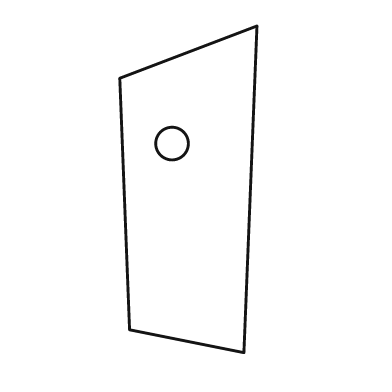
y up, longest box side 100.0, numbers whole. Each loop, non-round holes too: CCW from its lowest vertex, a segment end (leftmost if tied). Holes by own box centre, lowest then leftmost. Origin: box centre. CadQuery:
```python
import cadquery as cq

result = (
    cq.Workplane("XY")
    .moveTo(17.0, -50.0)
    .lineTo(21.0, 50.0)
    .lineTo(-21.0, 34.0)
    .lineTo(-18.0, -43.0)
    .close()
    .moveTo(-5.0, 14.0)
    .circle(5.0)
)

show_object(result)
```